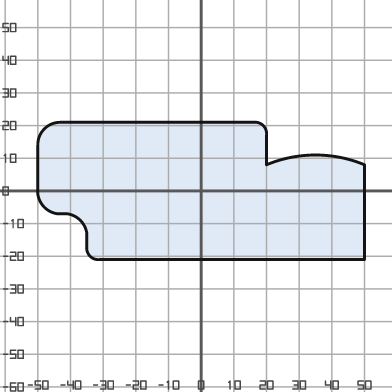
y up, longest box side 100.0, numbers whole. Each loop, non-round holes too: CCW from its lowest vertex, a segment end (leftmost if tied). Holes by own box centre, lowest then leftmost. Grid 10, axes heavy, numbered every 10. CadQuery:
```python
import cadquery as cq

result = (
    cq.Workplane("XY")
    .moveTo(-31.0, -21.0)
    .lineTo(50.0, -21.0)
    .lineTo(50.0, 8.0)
    .threePointArc((35.0, 11.0), (20.0, 8.0))
    .lineTo(20.0, 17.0)
    .threePointArc((19.0, 20.0), (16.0, 21.0))
    .lineTo(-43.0, 21.0)
    .threePointArc((-48.0, 19.0), (-50.0, 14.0))
    .lineTo(-50.0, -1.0)
    .threePointArc((-48.0, -5.0), (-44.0, -7.0))
    .lineTo(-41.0, -7.0)
    .threePointArc((-37.0, -9.0), (-35.0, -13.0))
    .lineTo(-35.0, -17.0)
    .threePointArc((-34.0, -20.0), (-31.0, -21.0))
    .close()
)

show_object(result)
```